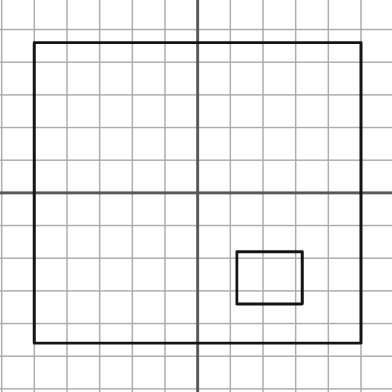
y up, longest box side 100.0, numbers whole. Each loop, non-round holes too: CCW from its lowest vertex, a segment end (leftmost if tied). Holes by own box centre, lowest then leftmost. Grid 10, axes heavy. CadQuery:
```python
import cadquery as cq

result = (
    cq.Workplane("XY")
    .moveTo(-50.0, -46.0)
    .lineTo(50.0, -46.0)
    .lineTo(50.0, 46.0)
    .lineTo(-50.0, 46.0)
    .close()
    .moveTo(12.0, -34.0)
    .lineTo(32.0, -34.0)
    .lineTo(32.0, -18.0)
    .lineTo(12.0, -18.0)
    .close()
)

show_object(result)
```